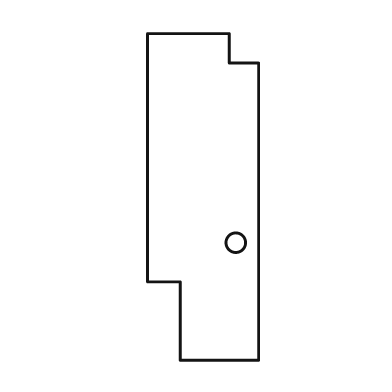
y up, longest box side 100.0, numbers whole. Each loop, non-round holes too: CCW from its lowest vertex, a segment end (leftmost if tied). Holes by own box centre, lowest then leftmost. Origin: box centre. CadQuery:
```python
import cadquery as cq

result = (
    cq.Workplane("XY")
    .moveTo(-7.0, -50.0)
    .lineTo(17.0, -50.0)
    .lineTo(17.0, 41.0)
    .lineTo(8.0, 41.0)
    .lineTo(8.0, 50.0)
    .lineTo(-17.0, 50.0)
    .lineTo(-17.0, -26.0)
    .lineTo(-7.0, -26.0)
    .close()
    .moveTo(10.0, -14.0)
    .circle(3.0)
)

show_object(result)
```